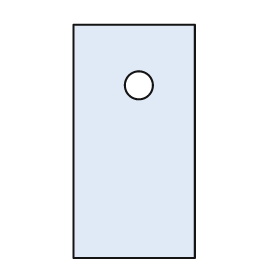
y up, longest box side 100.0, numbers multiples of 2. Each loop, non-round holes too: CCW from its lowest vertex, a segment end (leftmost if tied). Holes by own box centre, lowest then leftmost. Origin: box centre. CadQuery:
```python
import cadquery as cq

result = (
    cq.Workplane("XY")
    .moveTo(-26.0, -50.0)
    .lineTo(26.0, -50.0)
    .lineTo(26.0, 50.0)
    .lineTo(-26.0, 50.0)
    .close()
    .moveTo(2.0, 24.0)
    .circle(6.0)
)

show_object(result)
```